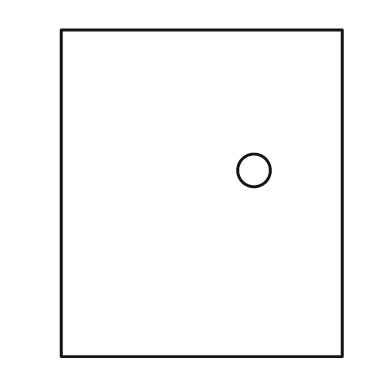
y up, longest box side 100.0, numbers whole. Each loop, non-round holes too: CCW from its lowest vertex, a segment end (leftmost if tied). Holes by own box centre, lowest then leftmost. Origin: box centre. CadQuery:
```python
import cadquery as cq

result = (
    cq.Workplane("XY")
    .moveTo(-43.0, -50.0)
    .lineTo(43.0, -50.0)
    .lineTo(43.0, 50.0)
    .lineTo(-43.0, 50.0)
    .close()
    .moveTo(16.0, 7.0)
    .circle(5.0)
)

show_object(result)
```